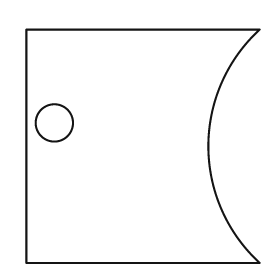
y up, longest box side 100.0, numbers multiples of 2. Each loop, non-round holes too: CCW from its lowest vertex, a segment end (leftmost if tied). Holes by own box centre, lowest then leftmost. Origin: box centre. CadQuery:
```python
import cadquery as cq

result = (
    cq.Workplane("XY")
    .moveTo(-50.0, -50.0)
    .lineTo(50.0, -50.0)
    .threePointArc((28.0, 0.0), (50.0, 50.0))
    .lineTo(-50.0, 50.0)
    .close()
    .moveTo(-38.0, 10.0)
    .circle(8.0)
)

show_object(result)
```